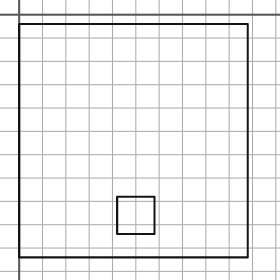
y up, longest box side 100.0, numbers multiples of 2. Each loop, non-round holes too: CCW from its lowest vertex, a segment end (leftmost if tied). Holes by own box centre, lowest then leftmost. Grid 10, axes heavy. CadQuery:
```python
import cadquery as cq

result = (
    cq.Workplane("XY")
    .moveTo(0.0, -104.0)
    .lineTo(98.0, -104.0)
    .lineTo(98.0, -4.0)
    .lineTo(0.0, -4.0)
    .close()
    .moveTo(42.0, -94.0)
    .lineTo(58.0, -94.0)
    .lineTo(58.0, -78.0)
    .lineTo(42.0, -78.0)
    .close()
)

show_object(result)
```